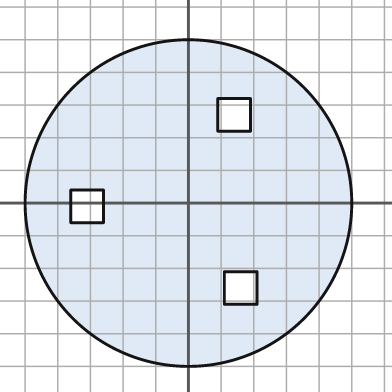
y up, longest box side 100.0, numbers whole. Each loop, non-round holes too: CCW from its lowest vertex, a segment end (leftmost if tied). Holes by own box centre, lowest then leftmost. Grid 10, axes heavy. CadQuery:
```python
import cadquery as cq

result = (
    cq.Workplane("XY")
    .moveTo(0.0, 0.0)
    .circle(50.0)
    .moveTo(11.0, -31.0)
    .lineTo(21.0, -31.0)
    .lineTo(21.0, -21.0)
    .lineTo(11.0, -21.0)
    .close()
    .moveTo(-36.0, -6.0)
    .lineTo(-26.0, -6.0)
    .lineTo(-26.0, 4.0)
    .lineTo(-36.0, 4.0)
    .close()
    .moveTo(9.0, 22.0)
    .lineTo(19.0, 22.0)
    .lineTo(19.0, 32.0)
    .lineTo(9.0, 32.0)
    .close()
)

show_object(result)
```